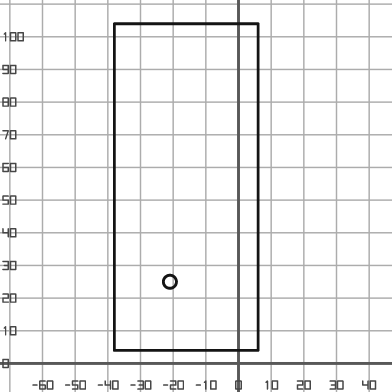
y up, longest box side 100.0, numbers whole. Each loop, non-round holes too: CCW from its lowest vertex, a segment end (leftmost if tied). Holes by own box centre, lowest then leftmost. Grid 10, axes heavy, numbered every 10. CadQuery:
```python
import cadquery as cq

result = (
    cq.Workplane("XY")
    .moveTo(-38.0, 4.0)
    .lineTo(6.0, 4.0)
    .lineTo(6.0, 104.0)
    .lineTo(-38.0, 104.0)
    .close()
    .moveTo(-21.0, 25.0)
    .circle(2.0)
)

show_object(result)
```